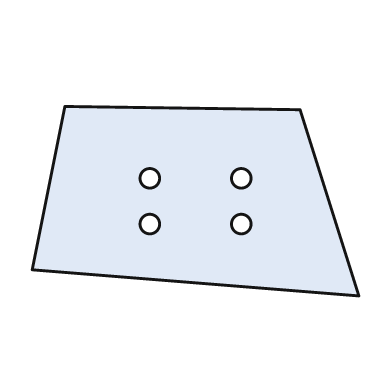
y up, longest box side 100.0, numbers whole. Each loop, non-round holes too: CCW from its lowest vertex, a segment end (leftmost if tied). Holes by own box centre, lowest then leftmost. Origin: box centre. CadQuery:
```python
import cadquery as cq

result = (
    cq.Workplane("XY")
    .moveTo(50.0, -29.0)
    .lineTo(32.0, 28.0)
    .lineTo(-40.0, 29.0)
    .lineTo(-50.0, -21.0)
    .close()
    .moveTo(-14.0, -7.0)
    .circle(3.0)
    .moveTo(14.0, -7.0)
    .circle(3.0)
    .moveTo(-14.0, 7.0)
    .circle(3.0)
    .moveTo(14.0, 7.0)
    .circle(3.0)
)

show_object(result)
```